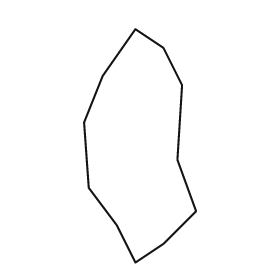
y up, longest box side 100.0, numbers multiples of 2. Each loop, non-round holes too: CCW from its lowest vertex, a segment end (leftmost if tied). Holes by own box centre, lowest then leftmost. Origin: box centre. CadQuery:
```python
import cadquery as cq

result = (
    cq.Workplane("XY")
    .moveTo(-2.0, -50.0)
    .lineTo(10.0, -42.0)
    .lineTo(24.0, -28.0)
    .lineTo(16.0, -6.0)
    .lineTo(18.0, 26.0)
    .lineTo(10.0, 42.0)
    .lineTo(-2.0, 50.0)
    .lineTo(-16.0, 30.0)
    .lineTo(-24.0, 10.0)
    .lineTo(-22.0, -18.0)
    .lineTo(-10.0, -34.0)
    .close()
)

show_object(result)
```